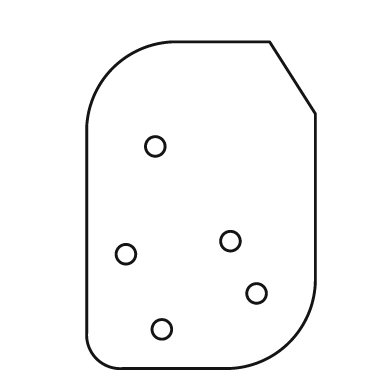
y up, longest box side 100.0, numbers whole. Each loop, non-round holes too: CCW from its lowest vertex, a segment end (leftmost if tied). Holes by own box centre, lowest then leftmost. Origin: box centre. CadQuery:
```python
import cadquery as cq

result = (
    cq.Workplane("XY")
    .moveTo(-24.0, -50.0)
    .lineTo(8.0, -50.0)
    .threePointArc((27.0, -42.0), (35.0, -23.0))
    .lineTo(35.0, 28.0)
    .lineTo(21.0, 50.0)
    .lineTo(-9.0, 50.0)
    .threePointArc((-27.0, 42.0), (-35.0, 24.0))
    .lineTo(-35.0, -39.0)
    .threePointArc((-32.0, -47.0), (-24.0, -50.0))
    .close()
    .moveTo(-12.0, -38.0)
    .circle(3.0)
    .moveTo(17.0, -27.0)
    .circle(3.0)
    .moveTo(-23.0, -15.0)
    .circle(3.0)
    .moveTo(9.0, -11.0)
    .circle(3.0)
    .moveTo(-14.0, 18.0)
    .circle(3.0)
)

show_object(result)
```